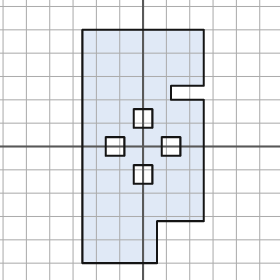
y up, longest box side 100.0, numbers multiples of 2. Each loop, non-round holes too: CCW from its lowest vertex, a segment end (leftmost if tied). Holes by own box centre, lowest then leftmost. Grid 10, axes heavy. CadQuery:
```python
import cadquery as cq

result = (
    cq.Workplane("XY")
    .moveTo(-26.0, -50.0)
    .lineTo(6.0, -50.0)
    .lineTo(6.0, -32.0)
    .lineTo(26.0, -32.0)
    .lineTo(26.0, 20.0)
    .lineTo(12.0, 20.0)
    .lineTo(12.0, 26.0)
    .lineTo(26.0, 26.0)
    .lineTo(26.0, 50.0)
    .lineTo(-26.0, 50.0)
    .close()
    .moveTo(-4.0, -16.0)
    .lineTo(4.0, -16.0)
    .lineTo(4.0, -8.0)
    .lineTo(-4.0, -8.0)
    .close()
    .moveTo(-16.0, -4.0)
    .lineTo(-8.0, -4.0)
    .lineTo(-8.0, 4.0)
    .lineTo(-16.0, 4.0)
    .close()
    .moveTo(8.0, -4.0)
    .lineTo(16.0, -4.0)
    .lineTo(16.0, 4.0)
    .lineTo(8.0, 4.0)
    .close()
    .moveTo(-4.0, 8.0)
    .lineTo(4.0, 8.0)
    .lineTo(4.0, 16.0)
    .lineTo(-4.0, 16.0)
    .close()
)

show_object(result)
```